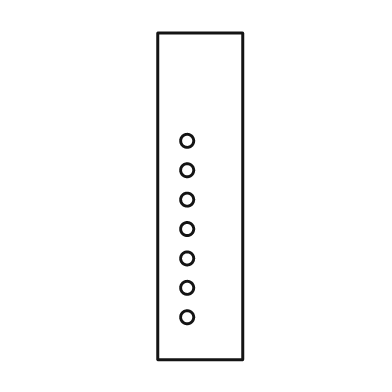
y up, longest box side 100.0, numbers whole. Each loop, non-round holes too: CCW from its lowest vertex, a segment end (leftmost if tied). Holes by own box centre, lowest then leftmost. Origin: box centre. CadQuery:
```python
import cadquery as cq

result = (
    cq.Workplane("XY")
    .moveTo(-13.0, -50.0)
    .lineTo(13.0, -50.0)
    .lineTo(13.0, 50.0)
    .lineTo(-13.0, 50.0)
    .close()
    .moveTo(-4.0, -37.0)
    .circle(2.0)
    .moveTo(-4.0, -28.0)
    .circle(2.0)
    .moveTo(-4.0, -19.0)
    .circle(2.0)
    .moveTo(-4.0, -10.0)
    .circle(2.0)
    .moveTo(-4.0, -1.0)
    .circle(2.0)
    .moveTo(-4.0, 8.0)
    .circle(2.0)
    .moveTo(-4.0, 17.0)
    .circle(2.0)
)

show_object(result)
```